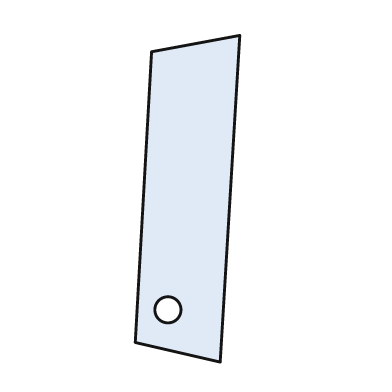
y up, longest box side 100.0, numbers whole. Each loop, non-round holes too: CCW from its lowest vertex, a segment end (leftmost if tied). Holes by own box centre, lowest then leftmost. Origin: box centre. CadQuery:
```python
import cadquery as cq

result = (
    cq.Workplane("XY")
    .moveTo(10.0, -50.0)
    .lineTo(16.0, 50.0)
    .lineTo(-11.0, 45.0)
    .lineTo(-16.0, -44.0)
    .close()
    .moveTo(-6.0, -34.0)
    .circle(4.0)
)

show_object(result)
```